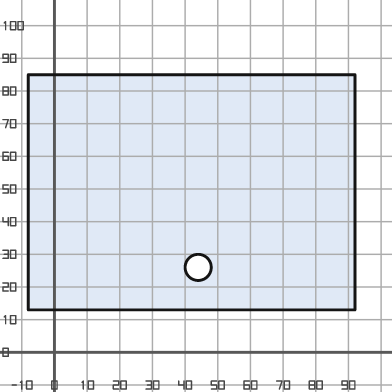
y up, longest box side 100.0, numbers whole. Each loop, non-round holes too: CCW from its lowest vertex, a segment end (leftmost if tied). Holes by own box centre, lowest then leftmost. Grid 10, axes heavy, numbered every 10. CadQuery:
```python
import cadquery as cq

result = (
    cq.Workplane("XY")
    .moveTo(-8.0, 13.0)
    .lineTo(92.0, 13.0)
    .lineTo(92.0, 85.0)
    .lineTo(-8.0, 85.0)
    .close()
    .moveTo(44.0, 26.0)
    .circle(4.0)
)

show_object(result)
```